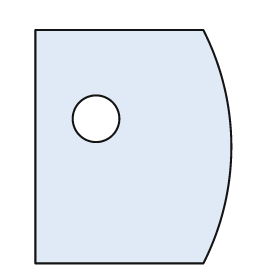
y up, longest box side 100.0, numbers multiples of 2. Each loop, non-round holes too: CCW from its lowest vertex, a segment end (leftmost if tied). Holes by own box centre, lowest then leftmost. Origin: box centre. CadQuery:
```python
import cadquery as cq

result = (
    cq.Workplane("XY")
    .moveTo(-42.0, -50.0)
    .lineTo(30.0, -50.0)
    .threePointArc((42.0, 0.0), (30.0, 50.0))
    .lineTo(-42.0, 50.0)
    .close()
    .moveTo(-16.0, 12.0)
    .circle(10.0)
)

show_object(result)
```